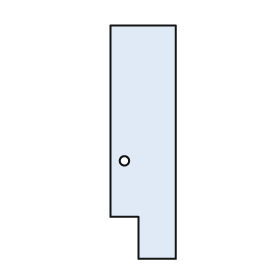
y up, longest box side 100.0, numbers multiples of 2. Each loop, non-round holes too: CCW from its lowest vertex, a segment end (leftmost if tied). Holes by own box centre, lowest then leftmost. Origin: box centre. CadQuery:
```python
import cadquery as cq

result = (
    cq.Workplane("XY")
    .moveTo(-2.0, -50.0)
    .lineTo(14.0, -50.0)
    .lineTo(14.0, 50.0)
    .lineTo(-14.0, 50.0)
    .lineTo(-14.0, -32.0)
    .lineTo(-2.0, -32.0)
    .close()
    .moveTo(-8.0, -8.0)
    .circle(2.0)
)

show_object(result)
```